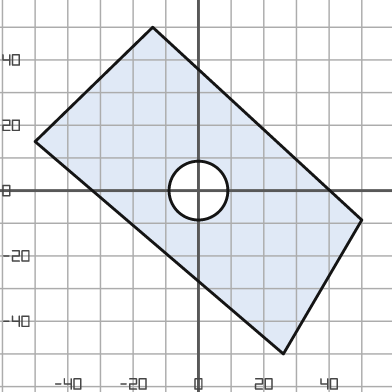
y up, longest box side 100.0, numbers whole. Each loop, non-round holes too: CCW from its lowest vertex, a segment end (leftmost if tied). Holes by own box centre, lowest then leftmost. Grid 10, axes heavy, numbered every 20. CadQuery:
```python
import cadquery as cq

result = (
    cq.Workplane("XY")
    .moveTo(26.0, -50.0)
    .lineTo(50.0, -9.0)
    .lineTo(-14.0, 50.0)
    .lineTo(-50.0, 15.0)
    .close()
    .moveTo(0.0, 0.0)
    .circle(9.0)
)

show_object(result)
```